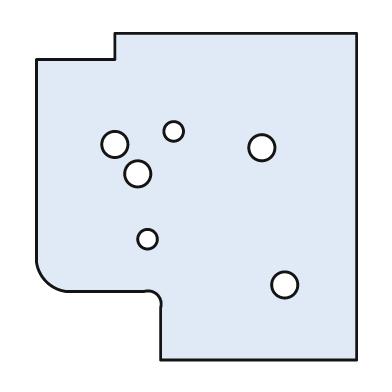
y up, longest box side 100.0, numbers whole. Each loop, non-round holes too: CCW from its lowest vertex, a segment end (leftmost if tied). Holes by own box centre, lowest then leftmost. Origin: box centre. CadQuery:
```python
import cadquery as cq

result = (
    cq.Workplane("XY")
    .moveTo(-11.0, -50.0)
    .lineTo(49.0, -50.0)
    .lineTo(49.0, 50.0)
    .lineTo(-25.0, 50.0)
    .lineTo(-25.0, 42.0)
    .lineTo(-49.0, 42.0)
    .lineTo(-49.0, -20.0)
    .threePointArc((-46.0, -26.0), (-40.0, -29.0))
    .lineTo(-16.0, -29.0)
    .threePointArc((-12.0, -30.0), (-11.0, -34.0))
    .close()
    .moveTo(27.0, -27.0)
    .circle(4.0)
    .moveTo(-15.0, -13.0)
    .circle(3.0)
    .moveTo(-18.0, 7.0)
    .circle(4.0)
    .moveTo(20.0, 15.0)
    .circle(4.0)
    .moveTo(-25.0, 16.0)
    .circle(4.0)
    .moveTo(-7.0, 20.0)
    .circle(3.0)
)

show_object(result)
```